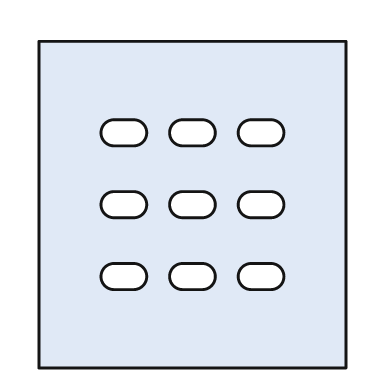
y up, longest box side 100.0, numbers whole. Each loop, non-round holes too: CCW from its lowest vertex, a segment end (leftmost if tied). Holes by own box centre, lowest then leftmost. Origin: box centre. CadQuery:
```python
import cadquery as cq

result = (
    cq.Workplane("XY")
    .moveTo(-47.0, -50.0)
    .lineTo(47.0, -50.0)
    .lineTo(47.0, 50.0)
    .lineTo(-47.0, 50.0)
    .close()
    .moveTo(-24.0, -26.0)
    .lineTo(-18.0, -26.0)
    .threePointArc((-14.0, -22.0), (-18.0, -18.0))
    .lineTo(-24.0, -18.0)
    .threePointArc((-28.0, -22.0), (-24.0, -26.0))
    .close()
    .moveTo(-3.0, -26.0)
    .lineTo(3.0, -26.0)
    .threePointArc((7.0, -22.0), (3.0, -18.0))
    .lineTo(-3.0, -18.0)
    .threePointArc((-7.0, -22.0), (-3.0, -26.0))
    .close()
    .moveTo(18.0, -26.0)
    .lineTo(24.0, -26.0)
    .threePointArc((28.0, -22.0), (24.0, -18.0))
    .lineTo(18.0, -18.0)
    .threePointArc((14.0, -22.0), (18.0, -26.0))
    .close()
    .moveTo(-24.0, -4.0)
    .lineTo(-18.0, -4.0)
    .threePointArc((-14.0, 0.0), (-18.0, 4.0))
    .lineTo(-24.0, 4.0)
    .threePointArc((-28.0, 0.0), (-24.0, -4.0))
    .close()
    .moveTo(-3.0, -4.0)
    .lineTo(3.0, -4.0)
    .threePointArc((7.0, 0.0), (3.0, 4.0))
    .lineTo(-3.0, 4.0)
    .threePointArc((-7.0, 0.0), (-3.0, -4.0))
    .close()
    .moveTo(18.0, -4.0)
    .lineTo(24.0, -4.0)
    .threePointArc((28.0, 0.0), (24.0, 4.0))
    .lineTo(18.0, 4.0)
    .threePointArc((14.0, 0.0), (18.0, -4.0))
    .close()
    .moveTo(-24.0, 18.0)
    .lineTo(-18.0, 18.0)
    .threePointArc((-14.0, 22.0), (-18.0, 26.0))
    .lineTo(-24.0, 26.0)
    .threePointArc((-28.0, 22.0), (-24.0, 18.0))
    .close()
    .moveTo(-3.0, 18.0)
    .lineTo(3.0, 18.0)
    .threePointArc((7.0, 22.0), (3.0, 26.0))
    .lineTo(-3.0, 26.0)
    .threePointArc((-7.0, 22.0), (-3.0, 18.0))
    .close()
    .moveTo(18.0, 18.0)
    .lineTo(24.0, 18.0)
    .threePointArc((28.0, 22.0), (24.0, 26.0))
    .lineTo(18.0, 26.0)
    .threePointArc((14.0, 22.0), (18.0, 18.0))
    .close()
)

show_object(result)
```